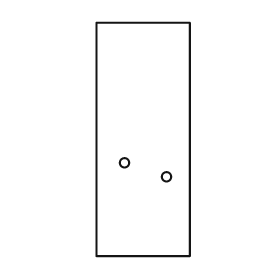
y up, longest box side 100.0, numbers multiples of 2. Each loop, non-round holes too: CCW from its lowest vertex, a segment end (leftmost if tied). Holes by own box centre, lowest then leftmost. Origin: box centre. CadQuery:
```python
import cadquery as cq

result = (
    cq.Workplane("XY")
    .moveTo(-20.0, -50.0)
    .lineTo(20.0, -50.0)
    .lineTo(20.0, 50.0)
    .lineTo(-20.0, 50.0)
    .close()
    .moveTo(10.0, -16.0)
    .circle(2.0)
    .moveTo(-8.0, -10.0)
    .circle(2.0)
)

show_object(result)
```